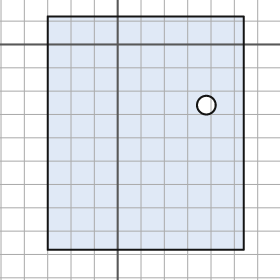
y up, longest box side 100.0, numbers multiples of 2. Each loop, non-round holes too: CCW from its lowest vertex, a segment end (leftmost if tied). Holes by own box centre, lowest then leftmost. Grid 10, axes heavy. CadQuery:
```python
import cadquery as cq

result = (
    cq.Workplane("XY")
    .moveTo(-30.0, -88.0)
    .lineTo(54.0, -88.0)
    .lineTo(54.0, 12.0)
    .lineTo(-30.0, 12.0)
    .close()
    .moveTo(38.0, -26.0)
    .circle(4.0)
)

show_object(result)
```